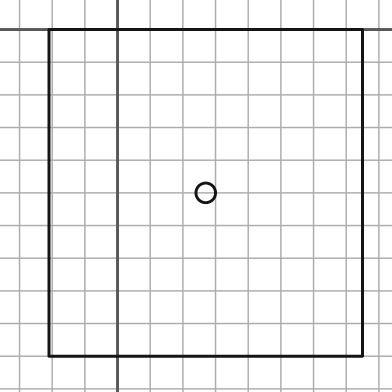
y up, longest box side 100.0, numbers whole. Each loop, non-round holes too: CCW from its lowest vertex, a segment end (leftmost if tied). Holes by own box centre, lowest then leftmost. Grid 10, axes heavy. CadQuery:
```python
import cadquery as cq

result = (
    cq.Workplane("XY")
    .moveTo(-21.0, -100.0)
    .lineTo(75.0, -100.0)
    .lineTo(75.0, 0.0)
    .lineTo(-21.0, 0.0)
    .close()
    .moveTo(27.0, -50.0)
    .circle(3.0)
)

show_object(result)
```